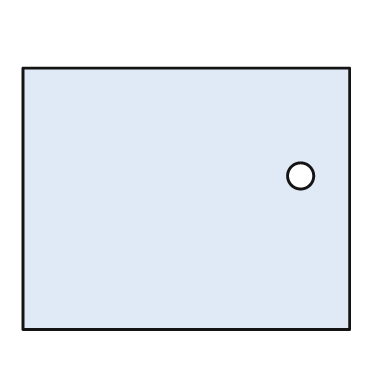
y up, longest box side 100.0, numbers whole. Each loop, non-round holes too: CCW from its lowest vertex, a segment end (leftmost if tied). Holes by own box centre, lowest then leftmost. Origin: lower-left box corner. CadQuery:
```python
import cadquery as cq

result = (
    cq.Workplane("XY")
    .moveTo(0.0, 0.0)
    .lineTo(100.0, 0.0)
    .lineTo(100.0, 80.0)
    .lineTo(0.0, 80.0)
    .close()
    .moveTo(85.0, 47.0)
    .circle(4.0)
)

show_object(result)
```